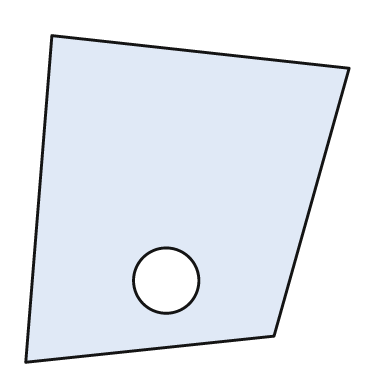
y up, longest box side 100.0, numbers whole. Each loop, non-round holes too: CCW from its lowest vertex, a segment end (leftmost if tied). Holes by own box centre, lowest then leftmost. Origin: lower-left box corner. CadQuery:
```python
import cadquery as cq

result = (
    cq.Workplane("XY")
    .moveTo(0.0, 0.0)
    .lineTo(76.0, 8.0)
    .lineTo(99.0, 90.0)
    .lineTo(8.0, 100.0)
    .close()
    .moveTo(43.0, 25.0)
    .circle(10.0)
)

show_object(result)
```